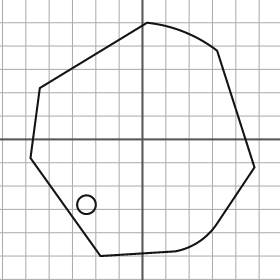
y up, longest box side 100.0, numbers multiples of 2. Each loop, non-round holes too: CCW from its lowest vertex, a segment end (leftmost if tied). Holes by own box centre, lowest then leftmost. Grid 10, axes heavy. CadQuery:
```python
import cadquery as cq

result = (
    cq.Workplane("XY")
    .moveTo(-18.0, -50.0)
    .lineTo(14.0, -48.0)
    .threePointArc((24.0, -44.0), (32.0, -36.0))
    .lineTo(48.0, -12.0)
    .lineTo(32.0, 38.0)
    .threePointArc((18.0, 46.0), (2.0, 50.0))
    .lineTo(-44.0, 22.0)
    .lineTo(-48.0, -8.0)
    .close()
    .moveTo(-24.0, -28.0)
    .circle(4.0)
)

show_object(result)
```